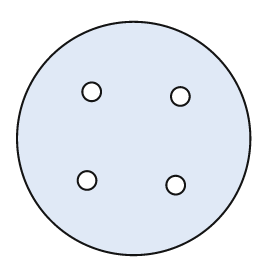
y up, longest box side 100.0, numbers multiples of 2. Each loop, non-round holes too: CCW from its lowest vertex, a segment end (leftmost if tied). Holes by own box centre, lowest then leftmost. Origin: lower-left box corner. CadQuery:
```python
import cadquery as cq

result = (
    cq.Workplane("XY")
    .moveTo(50.0, 50.0)
    .circle(50.0)
    .moveTo(68.0, 30.0)
    .circle(4.0)
    .moveTo(30.0, 32.0)
    .circle(4.0)
    .moveTo(70.0, 68.0)
    .circle(4.0)
    .moveTo(32.0, 70.0)
    .circle(4.0)
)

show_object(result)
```